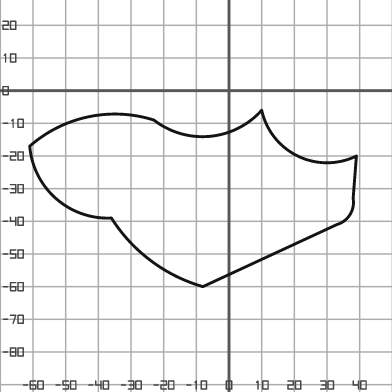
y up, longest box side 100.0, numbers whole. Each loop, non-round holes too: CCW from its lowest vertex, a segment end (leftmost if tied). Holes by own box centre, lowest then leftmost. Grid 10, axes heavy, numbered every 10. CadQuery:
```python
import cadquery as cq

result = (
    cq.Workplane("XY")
    .moveTo(-8.0, -60.0)
    .lineTo(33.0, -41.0)
    .threePointArc((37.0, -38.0), (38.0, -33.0))
    .lineTo(39.0, -20.0)
    .threePointArc((21.0, -20.0), (10.0, -6.0))
    .threePointArc((-6.0, -14.0), (-23.0, -9.0))
    .threePointArc((-43.0, -8.0), (-61.0, -17.0))
    .threePointArc((-53.0, -33.0), (-36.0, -39.0))
    .threePointArc((-24.0, -52.0), (-8.0, -60.0))
    .close()
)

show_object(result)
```